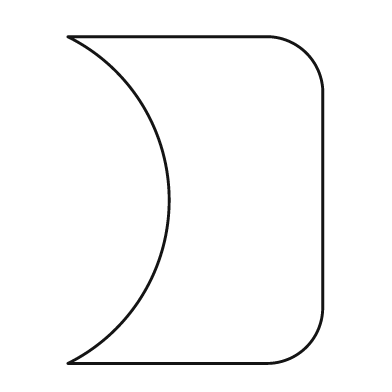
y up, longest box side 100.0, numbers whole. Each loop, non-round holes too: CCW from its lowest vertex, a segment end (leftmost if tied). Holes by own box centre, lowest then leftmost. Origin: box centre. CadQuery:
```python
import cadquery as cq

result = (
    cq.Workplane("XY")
    .moveTo(-39.0, -50.0)
    .lineTo(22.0, -50.0)
    .threePointArc((34.0, -45.0), (39.0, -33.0))
    .lineTo(39.0, 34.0)
    .threePointArc((34.0, 45.0), (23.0, 50.0))
    .lineTo(-39.0, 50.0)
    .threePointArc((-8.0, 0.0), (-39.0, -50.0))
    .close()
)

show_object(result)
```